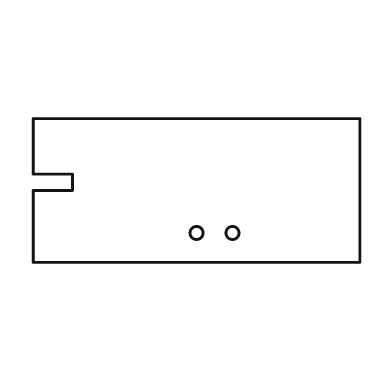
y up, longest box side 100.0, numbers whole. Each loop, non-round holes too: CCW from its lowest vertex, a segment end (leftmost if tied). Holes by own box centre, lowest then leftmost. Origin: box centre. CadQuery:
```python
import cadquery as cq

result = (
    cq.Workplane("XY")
    .moveTo(-50.0, -22.0)
    .lineTo(50.0, -22.0)
    .lineTo(50.0, 22.0)
    .lineTo(-50.0, 22.0)
    .lineTo(-50.0, 5.0)
    .lineTo(-38.0, 5.0)
    .lineTo(-38.0, 0.0)
    .lineTo(-50.0, 0.0)
    .close()
    .moveTo(0.0, -13.0)
    .circle(2.0)
    .moveTo(11.0, -13.0)
    .circle(2.0)
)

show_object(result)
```